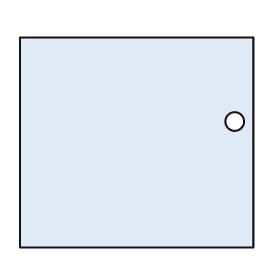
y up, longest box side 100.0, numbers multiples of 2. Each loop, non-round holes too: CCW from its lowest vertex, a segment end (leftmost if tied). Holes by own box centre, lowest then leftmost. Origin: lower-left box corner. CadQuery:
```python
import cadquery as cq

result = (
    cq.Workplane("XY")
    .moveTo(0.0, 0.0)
    .lineTo(100.0, 0.0)
    .lineTo(100.0, 90.0)
    .lineTo(0.0, 90.0)
    .close()
    .moveTo(92.0, 54.0)
    .circle(4.0)
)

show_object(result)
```